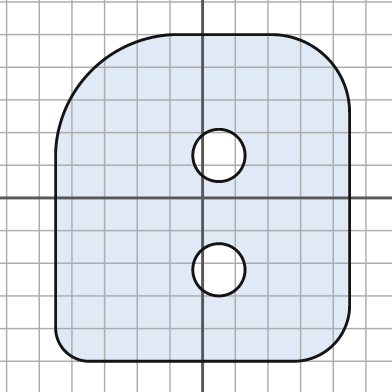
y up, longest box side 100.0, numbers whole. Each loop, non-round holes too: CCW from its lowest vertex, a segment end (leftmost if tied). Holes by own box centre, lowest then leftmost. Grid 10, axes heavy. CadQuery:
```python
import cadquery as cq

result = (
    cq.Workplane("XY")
    .moveTo(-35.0, -50.0)
    .lineTo(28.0, -50.0)
    .threePointArc((40.0, -45.0), (45.0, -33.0))
    .lineTo(45.0, 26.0)
    .threePointArc((38.0, 43.0), (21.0, 50.0))
    .lineTo(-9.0, 50.0)
    .threePointArc((-34.0, 39.0), (-45.0, 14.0))
    .lineTo(-45.0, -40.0)
    .threePointArc((-42.0, -47.0), (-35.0, -50.0))
    .close()
    .moveTo(5.0, -22.0)
    .circle(8.0)
    .moveTo(5.0, 13.0)
    .circle(8.0)
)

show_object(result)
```